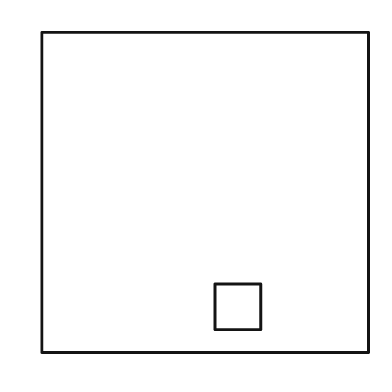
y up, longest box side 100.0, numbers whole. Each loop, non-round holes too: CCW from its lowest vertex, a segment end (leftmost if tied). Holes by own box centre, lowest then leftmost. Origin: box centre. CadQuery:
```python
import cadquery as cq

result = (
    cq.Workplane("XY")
    .moveTo(-50.0, -49.0)
    .lineTo(50.0, -49.0)
    .lineTo(50.0, 49.0)
    .lineTo(-50.0, 49.0)
    .close()
    .moveTo(3.0, -42.0)
    .lineTo(17.0, -42.0)
    .lineTo(17.0, -28.0)
    .lineTo(3.0, -28.0)
    .close()
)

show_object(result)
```